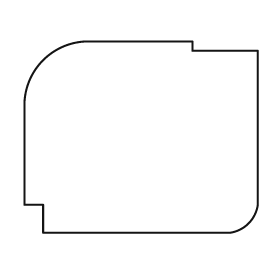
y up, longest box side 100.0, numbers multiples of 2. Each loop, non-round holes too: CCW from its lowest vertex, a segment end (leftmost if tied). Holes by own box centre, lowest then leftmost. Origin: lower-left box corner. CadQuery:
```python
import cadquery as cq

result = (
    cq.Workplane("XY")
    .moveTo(8.0, 0.0)
    .lineTo(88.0, 0.0)
    .threePointArc((96.0, 4.0), (100.0, 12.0))
    .lineTo(100.0, 78.0)
    .lineTo(72.0, 78.0)
    .lineTo(72.0, 82.0)
    .lineTo(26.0, 82.0)
    .threePointArc((8.0, 74.0), (0.0, 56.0))
    .lineTo(0.0, 12.0)
    .lineTo(8.0, 12.0)
    .close()
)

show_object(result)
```